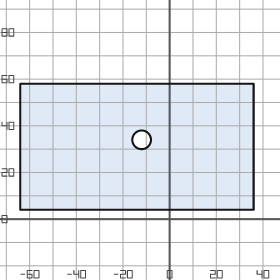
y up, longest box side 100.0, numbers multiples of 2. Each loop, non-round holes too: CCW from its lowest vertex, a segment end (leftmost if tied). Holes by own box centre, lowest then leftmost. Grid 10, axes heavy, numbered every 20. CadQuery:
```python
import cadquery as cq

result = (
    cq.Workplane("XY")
    .moveTo(-64.0, 4.0)
    .lineTo(36.0, 4.0)
    .lineTo(36.0, 58.0)
    .lineTo(-64.0, 58.0)
    .close()
    .moveTo(-12.0, 34.0)
    .circle(4.0)
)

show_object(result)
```